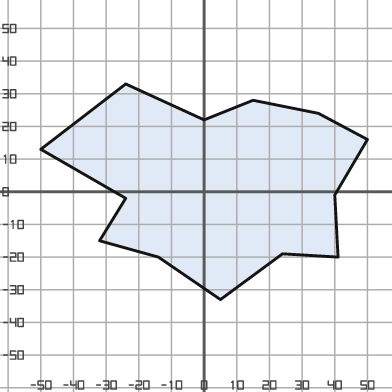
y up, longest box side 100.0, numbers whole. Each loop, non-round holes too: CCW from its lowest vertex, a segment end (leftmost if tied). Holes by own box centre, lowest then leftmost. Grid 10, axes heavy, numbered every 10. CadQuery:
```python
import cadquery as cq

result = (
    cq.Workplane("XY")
    .moveTo(5.0, -33.0)
    .lineTo(24.0, -19.0)
    .lineTo(41.0, -20.0)
    .lineTo(40.0, -1.0)
    .lineTo(50.0, 16.0)
    .lineTo(35.0, 24.0)
    .lineTo(15.0, 28.0)
    .lineTo(0.0, 22.0)
    .lineTo(-24.0, 33.0)
    .lineTo(-50.0, 13.0)
    .lineTo(-24.0, -2.0)
    .lineTo(-32.0, -15.0)
    .lineTo(-14.0, -20.0)
    .close()
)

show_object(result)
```